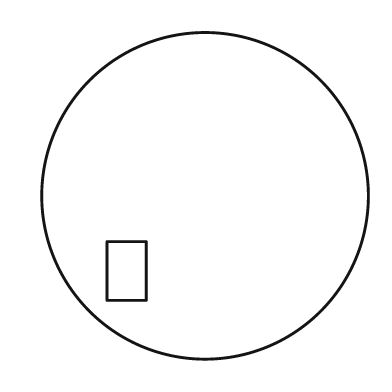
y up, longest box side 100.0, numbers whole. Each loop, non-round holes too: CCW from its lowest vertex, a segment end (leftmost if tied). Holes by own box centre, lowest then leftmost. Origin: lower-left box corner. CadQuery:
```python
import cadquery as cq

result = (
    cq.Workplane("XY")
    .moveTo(50.0, 50.0)
    .circle(50.0)
    .moveTo(20.0, 18.0)
    .lineTo(32.0, 18.0)
    .lineTo(32.0, 36.0)
    .lineTo(20.0, 36.0)
    .close()
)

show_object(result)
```